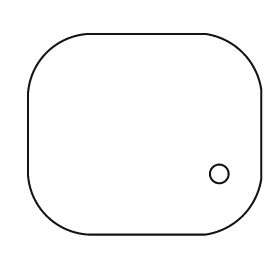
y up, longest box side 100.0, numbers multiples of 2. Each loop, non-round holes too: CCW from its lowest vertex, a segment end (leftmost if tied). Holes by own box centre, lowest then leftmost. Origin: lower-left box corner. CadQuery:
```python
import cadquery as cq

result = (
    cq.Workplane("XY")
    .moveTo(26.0, 0.0)
    .lineTo(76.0, 0.0)
    .threePointArc((92.0, 8.0), (100.0, 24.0))
    .lineTo(100.0, 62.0)
    .threePointArc((92.0, 78.0), (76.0, 86.0))
    .lineTo(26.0, 86.0)
    .threePointArc((8.0, 78.0), (0.0, 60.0))
    .lineTo(0.0, 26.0)
    .threePointArc((8.0, 8.0), (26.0, 0.0))
    .close()
    .moveTo(82.0, 26.0)
    .circle(4.0)
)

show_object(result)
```